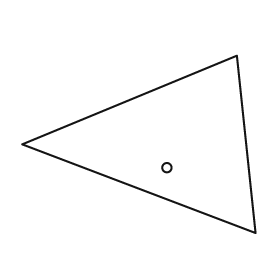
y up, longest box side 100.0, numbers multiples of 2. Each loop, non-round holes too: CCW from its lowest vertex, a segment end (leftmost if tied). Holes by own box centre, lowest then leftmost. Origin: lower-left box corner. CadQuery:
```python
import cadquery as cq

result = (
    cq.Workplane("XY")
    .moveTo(100.0, 0.0)
    .lineTo(92.0, 76.0)
    .lineTo(0.0, 38.0)
    .close()
    .moveTo(62.0, 28.0)
    .circle(2.0)
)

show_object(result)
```